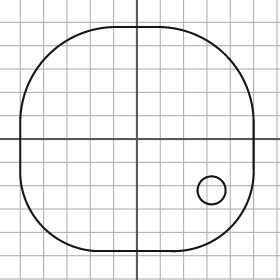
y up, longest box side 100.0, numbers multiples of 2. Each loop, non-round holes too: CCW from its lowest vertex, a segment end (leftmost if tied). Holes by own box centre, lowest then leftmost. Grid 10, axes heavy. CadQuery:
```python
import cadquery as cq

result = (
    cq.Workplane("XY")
    .moveTo(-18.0, -48.0)
    .lineTo(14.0, -48.0)
    .threePointArc((40.0, -38.0), (50.0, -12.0))
    .lineTo(50.0, 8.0)
    .threePointArc((38.0, 36.0), (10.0, 48.0))
    .lineTo(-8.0, 48.0)
    .threePointArc((-38.0, 36.0), (-50.0, 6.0))
    .lineTo(-50.0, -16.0)
    .threePointArc((-40.0, -38.0), (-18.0, -48.0))
    .close()
    .moveTo(32.0, -22.0)
    .circle(6.0)
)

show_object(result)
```